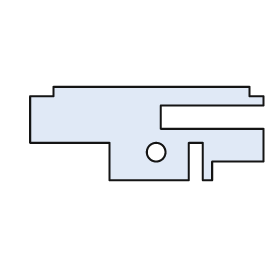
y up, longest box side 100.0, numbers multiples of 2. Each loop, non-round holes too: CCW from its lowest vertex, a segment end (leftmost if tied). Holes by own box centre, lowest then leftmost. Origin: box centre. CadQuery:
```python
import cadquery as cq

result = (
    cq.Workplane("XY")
    .moveTo(-16.0, -20.0)
    .lineTo(18.0, -20.0)
    .lineTo(18.0, -4.0)
    .lineTo(24.0, -4.0)
    .lineTo(24.0, -20.0)
    .lineTo(28.0, -20.0)
    .lineTo(28.0, -12.0)
    .lineTo(50.0, -12.0)
    .lineTo(50.0, 2.0)
    .lineTo(6.0, 2.0)
    .lineTo(6.0, 12.0)
    .lineTo(50.0, 12.0)
    .lineTo(50.0, 16.0)
    .lineTo(44.0, 16.0)
    .lineTo(44.0, 20.0)
    .lineTo(-40.0, 20.0)
    .lineTo(-40.0, 16.0)
    .lineTo(-50.0, 16.0)
    .lineTo(-50.0, -4.0)
    .lineTo(-16.0, -4.0)
    .close()
    .moveTo(4.0, -8.0)
    .circle(4.0)
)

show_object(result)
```